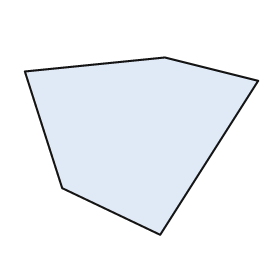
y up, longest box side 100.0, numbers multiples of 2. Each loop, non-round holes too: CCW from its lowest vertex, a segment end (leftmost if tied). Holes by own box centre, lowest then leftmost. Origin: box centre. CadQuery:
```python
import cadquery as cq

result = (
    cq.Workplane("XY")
    .moveTo(8.0, -38.0)
    .lineTo(50.0, 28.0)
    .lineTo(10.0, 38.0)
    .lineTo(-50.0, 32.0)
    .lineTo(-34.0, -18.0)
    .close()
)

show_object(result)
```